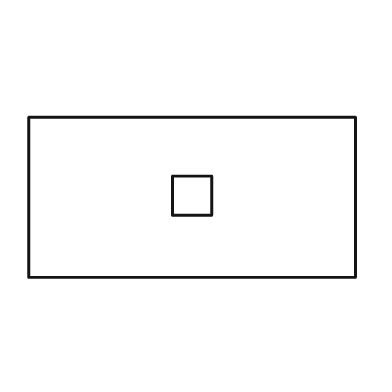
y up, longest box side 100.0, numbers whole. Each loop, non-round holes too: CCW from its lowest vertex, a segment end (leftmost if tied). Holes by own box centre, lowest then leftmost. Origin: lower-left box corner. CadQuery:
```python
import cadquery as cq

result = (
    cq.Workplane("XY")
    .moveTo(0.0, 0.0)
    .lineTo(100.0, 0.0)
    .lineTo(100.0, 49.0)
    .lineTo(0.0, 49.0)
    .close()
    .moveTo(44.0, 19.0)
    .lineTo(56.0, 19.0)
    .lineTo(56.0, 31.0)
    .lineTo(44.0, 31.0)
    .close()
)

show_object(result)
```